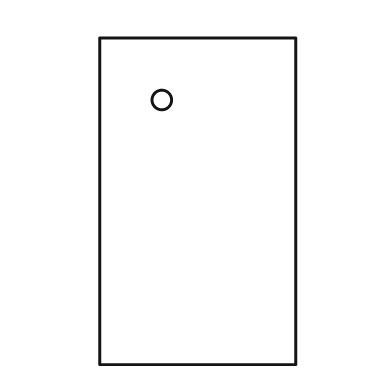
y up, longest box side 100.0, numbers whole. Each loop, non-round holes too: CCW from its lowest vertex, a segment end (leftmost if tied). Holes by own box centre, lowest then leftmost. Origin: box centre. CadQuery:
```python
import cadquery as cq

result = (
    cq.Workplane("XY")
    .moveTo(-30.0, -50.0)
    .lineTo(30.0, -50.0)
    .lineTo(30.0, 50.0)
    .lineTo(-30.0, 50.0)
    .close()
    .moveTo(-11.0, 31.0)
    .circle(3.0)
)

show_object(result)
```